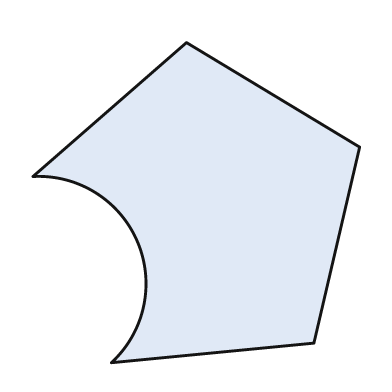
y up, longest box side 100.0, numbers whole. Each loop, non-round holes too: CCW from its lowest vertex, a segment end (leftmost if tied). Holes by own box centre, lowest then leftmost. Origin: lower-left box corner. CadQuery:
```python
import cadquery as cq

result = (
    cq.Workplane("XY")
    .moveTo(24.0, 0.0)
    .lineTo(86.0, 6.0)
    .lineTo(100.0, 66.0)
    .lineTo(47.0, 98.0)
    .lineTo(0.0, 57.0)
    .threePointArc((32.0, 37.0), (24.0, 0.0))
    .close()
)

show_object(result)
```